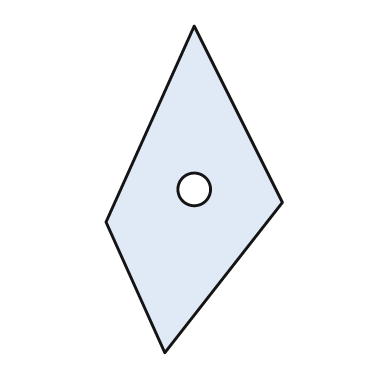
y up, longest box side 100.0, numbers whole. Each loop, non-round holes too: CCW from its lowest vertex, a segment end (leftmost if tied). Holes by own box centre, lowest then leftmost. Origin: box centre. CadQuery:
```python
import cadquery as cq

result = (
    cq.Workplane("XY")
    .moveTo(-9.0, -50.0)
    .lineTo(27.0, -4.0)
    .lineTo(0.0, 50.0)
    .lineTo(-27.0, -10.0)
    .close()
    .moveTo(0.0, 0.0)
    .circle(5.0)
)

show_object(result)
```